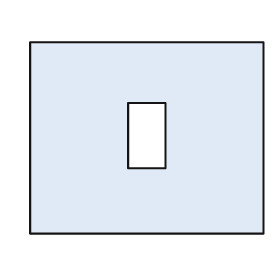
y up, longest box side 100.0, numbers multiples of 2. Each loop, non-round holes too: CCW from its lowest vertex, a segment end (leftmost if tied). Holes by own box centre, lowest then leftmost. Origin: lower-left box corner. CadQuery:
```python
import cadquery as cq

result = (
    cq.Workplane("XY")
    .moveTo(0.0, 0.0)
    .lineTo(100.0, 0.0)
    .lineTo(100.0, 82.0)
    .lineTo(0.0, 82.0)
    .close()
    .moveTo(42.0, 28.0)
    .lineTo(58.0, 28.0)
    .lineTo(58.0, 56.0)
    .lineTo(42.0, 56.0)
    .close()
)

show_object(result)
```